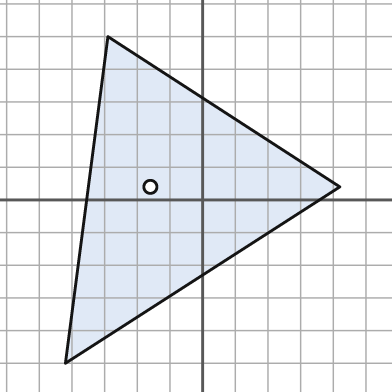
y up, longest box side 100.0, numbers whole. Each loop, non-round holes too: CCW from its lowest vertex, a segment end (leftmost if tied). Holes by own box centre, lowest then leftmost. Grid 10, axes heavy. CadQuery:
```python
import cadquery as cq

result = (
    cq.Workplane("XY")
    .moveTo(-42.0, -50.0)
    .lineTo(42.0, 4.0)
    .lineTo(-29.0, 50.0)
    .close()
    .moveTo(-16.0, 4.0)
    .circle(2.0)
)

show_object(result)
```